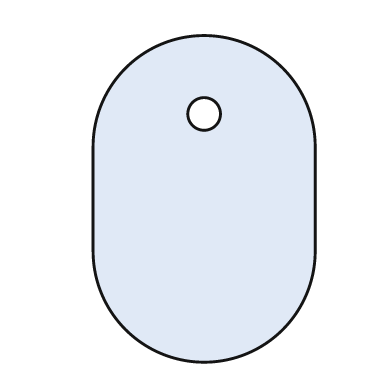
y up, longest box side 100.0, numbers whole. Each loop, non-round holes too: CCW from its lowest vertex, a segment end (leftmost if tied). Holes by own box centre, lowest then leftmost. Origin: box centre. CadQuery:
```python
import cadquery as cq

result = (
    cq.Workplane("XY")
    .moveTo(-34.0, -16.0)
    .threePointArc((0.0, -50.0), (34.0, -16.0))
    .lineTo(34.0, 16.0)
    .threePointArc((0.0, 50.0), (-34.0, 16.0))
    .close()
    .moveTo(0.0, 26.0)
    .circle(5.0)
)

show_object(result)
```